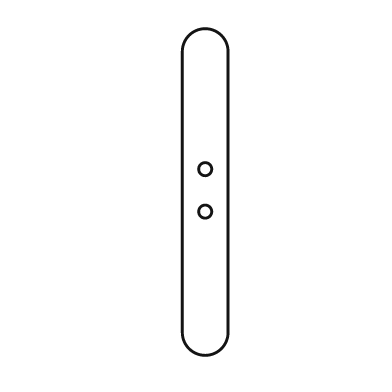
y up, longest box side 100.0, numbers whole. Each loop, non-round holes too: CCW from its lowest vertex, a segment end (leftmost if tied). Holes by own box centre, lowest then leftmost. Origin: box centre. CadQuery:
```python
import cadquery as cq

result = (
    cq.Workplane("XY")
    .moveTo(-7.0, -43.0)
    .threePointArc((0.0, -50.0), (7.0, -43.0))
    .lineTo(7.0, 43.0)
    .threePointArc((0.0, 50.0), (-7.0, 43.0))
    .close()
    .moveTo(0.0, -6.0)
    .circle(2.0)
    .moveTo(0.0, 7.0)
    .circle(2.0)
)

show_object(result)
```